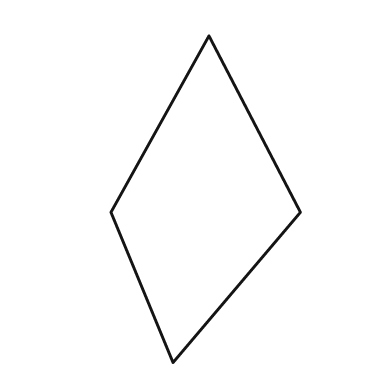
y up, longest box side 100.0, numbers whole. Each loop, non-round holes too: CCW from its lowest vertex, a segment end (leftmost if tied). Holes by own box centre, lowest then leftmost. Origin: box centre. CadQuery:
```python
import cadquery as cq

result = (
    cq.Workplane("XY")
    .moveTo(-10.0, -50.0)
    .lineTo(29.0, -4.0)
    .lineTo(1.0, 50.0)
    .lineTo(-29.0, -4.0)
    .close()
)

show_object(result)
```